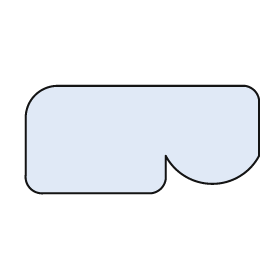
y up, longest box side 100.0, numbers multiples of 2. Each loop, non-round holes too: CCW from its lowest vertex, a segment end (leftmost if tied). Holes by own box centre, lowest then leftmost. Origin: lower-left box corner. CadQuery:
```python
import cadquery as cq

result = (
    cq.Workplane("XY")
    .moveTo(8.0, 0.0)
    .lineTo(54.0, 0.0)
    .threePointArc((58.0, 2.0), (60.0, 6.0))
    .lineTo(60.0, 16.0)
    .threePointArc((80.0, 4.0), (100.0, 16.0))
    .lineTo(100.0, 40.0)
    .threePointArc((98.0, 44.0), (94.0, 46.0))
    .lineTo(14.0, 46.0)
    .threePointArc((4.0, 42.0), (0.0, 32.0))
    .lineTo(0.0, 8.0)
    .threePointArc((2.0, 2.0), (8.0, 0.0))
    .close()
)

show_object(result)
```